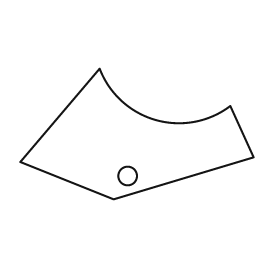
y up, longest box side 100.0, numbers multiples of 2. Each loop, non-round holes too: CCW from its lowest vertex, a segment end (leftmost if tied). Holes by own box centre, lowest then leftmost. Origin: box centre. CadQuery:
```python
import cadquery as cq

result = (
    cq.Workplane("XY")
    .moveTo(-10.0, -28.0)
    .lineTo(50.0, -10.0)
    .lineTo(40.0, 12.0)
    .threePointArc((8.0, 6.0), (-16.0, 28.0))
    .lineTo(-50.0, -12.0)
    .close()
    .moveTo(-4.0, -18.0)
    .circle(4.0)
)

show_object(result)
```